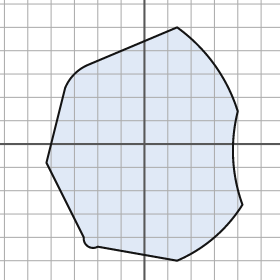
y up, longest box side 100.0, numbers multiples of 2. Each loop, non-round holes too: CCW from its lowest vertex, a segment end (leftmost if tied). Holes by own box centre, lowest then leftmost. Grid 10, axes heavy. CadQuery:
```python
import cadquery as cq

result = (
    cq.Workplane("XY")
    .moveTo(14.0, -50.0)
    .threePointArc((30.0, -40.0), (42.0, -26.0))
    .threePointArc((38.0, -6.0), (40.0, 14.0))
    .threePointArc((30.0, 34.0), (14.0, 50.0))
    .lineTo(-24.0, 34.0)
    .threePointArc((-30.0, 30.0), (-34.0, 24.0))
    .lineTo(-42.0, -8.0)
    .lineTo(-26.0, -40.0)
    .threePointArc((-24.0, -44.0), (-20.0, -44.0))
    .close()
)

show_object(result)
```